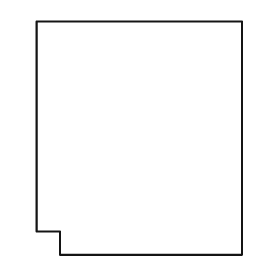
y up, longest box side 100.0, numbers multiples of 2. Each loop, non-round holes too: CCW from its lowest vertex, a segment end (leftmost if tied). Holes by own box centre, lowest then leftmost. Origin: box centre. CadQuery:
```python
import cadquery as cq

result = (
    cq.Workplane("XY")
    .moveTo(-34.0, -50.0)
    .lineTo(44.0, -50.0)
    .lineTo(44.0, 50.0)
    .lineTo(-44.0, 50.0)
    .lineTo(-44.0, -40.0)
    .lineTo(-34.0, -40.0)
    .close()
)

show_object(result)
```